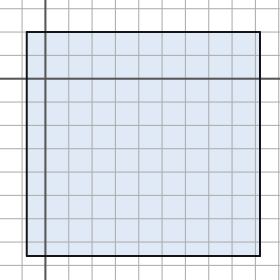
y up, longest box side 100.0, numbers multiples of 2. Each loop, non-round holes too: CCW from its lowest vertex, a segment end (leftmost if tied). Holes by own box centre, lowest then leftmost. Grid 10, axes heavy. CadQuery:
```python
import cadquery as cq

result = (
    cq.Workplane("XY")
    .moveTo(-8.0, -76.0)
    .lineTo(92.0, -76.0)
    .lineTo(92.0, 20.0)
    .lineTo(-8.0, 20.0)
    .close()
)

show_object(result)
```